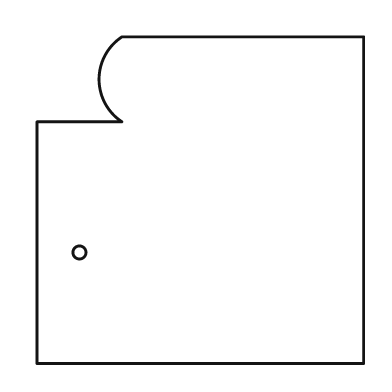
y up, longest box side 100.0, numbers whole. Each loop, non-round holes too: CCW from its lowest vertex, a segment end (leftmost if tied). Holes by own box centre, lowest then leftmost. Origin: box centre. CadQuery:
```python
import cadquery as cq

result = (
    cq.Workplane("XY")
    .moveTo(-50.0, -50.0)
    .lineTo(50.0, -50.0)
    .lineTo(50.0, 50.0)
    .lineTo(-24.0, 50.0)
    .threePointArc((-31.0, 37.0), (-24.0, 24.0))
    .lineTo(-50.0, 24.0)
    .close()
    .moveTo(-37.0, -16.0)
    .circle(2.0)
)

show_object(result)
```